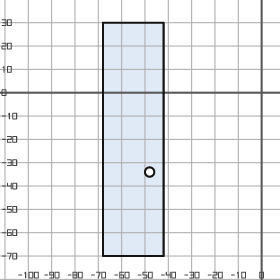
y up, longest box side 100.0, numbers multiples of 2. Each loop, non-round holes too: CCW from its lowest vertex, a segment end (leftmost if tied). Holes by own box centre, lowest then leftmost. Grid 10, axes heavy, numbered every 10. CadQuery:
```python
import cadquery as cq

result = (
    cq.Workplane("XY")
    .moveTo(-68.0, -70.0)
    .lineTo(-42.0, -70.0)
    .lineTo(-42.0, 30.0)
    .lineTo(-68.0, 30.0)
    .close()
    .moveTo(-48.0, -34.0)
    .circle(2.0)
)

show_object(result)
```